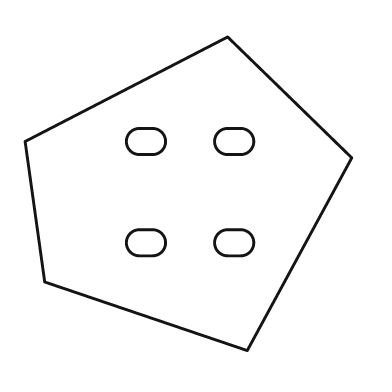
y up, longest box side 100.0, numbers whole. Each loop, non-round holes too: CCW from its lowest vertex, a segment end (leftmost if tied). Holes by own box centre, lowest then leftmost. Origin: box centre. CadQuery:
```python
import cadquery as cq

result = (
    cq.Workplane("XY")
    .moveTo(18.0, -48.0)
    .lineTo(50.0, 11.0)
    .lineTo(12.0, 48.0)
    .lineTo(-50.0, 16.0)
    .lineTo(-44.0, -27.0)
    .close()
    .moveTo(-15.0, -19.0)
    .lineTo(-11.0, -19.0)
    .threePointArc((-7.0, -15.0), (-11.0, -11.0))
    .lineTo(-15.0, -11.0)
    .threePointArc((-19.0, -15.0), (-15.0, -19.0))
    .close()
    .moveTo(12.0, -19.0)
    .lineTo(16.0, -19.0)
    .threePointArc((20.0, -15.0), (16.0, -11.0))
    .lineTo(12.0, -11.0)
    .threePointArc((8.0, -15.0), (12.0, -19.0))
    .close()
    .moveTo(-15.0, 12.0)
    .lineTo(-11.0, 12.0)
    .threePointArc((-7.0, 16.0), (-11.0, 20.0))
    .lineTo(-15.0, 20.0)
    .threePointArc((-19.0, 16.0), (-15.0, 12.0))
    .close()
    .moveTo(12.0, 12.0)
    .lineTo(16.0, 12.0)
    .threePointArc((20.0, 16.0), (16.0, 20.0))
    .lineTo(12.0, 20.0)
    .threePointArc((8.0, 16.0), (12.0, 12.0))
    .close()
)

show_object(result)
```